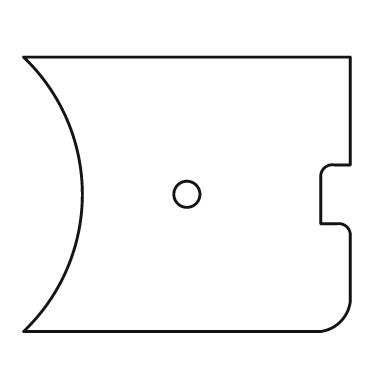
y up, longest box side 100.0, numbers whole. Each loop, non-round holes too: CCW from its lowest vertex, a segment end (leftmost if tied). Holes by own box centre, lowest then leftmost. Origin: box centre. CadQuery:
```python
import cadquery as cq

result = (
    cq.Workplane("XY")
    .moveTo(-50.0, -42.0)
    .lineTo(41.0, -42.0)
    .threePointArc((47.0, -39.0), (50.0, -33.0))
    .lineTo(50.0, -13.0)
    .threePointArc((49.0, -10.0), (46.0, -9.0))
    .lineTo(41.0, -9.0)
    .lineTo(41.0, 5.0)
    .threePointArc((42.0, 8.0), (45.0, 9.0))
    .lineTo(50.0, 9.0)
    .lineTo(50.0, 42.0)
    .lineTo(-50.0, 42.0)
    .threePointArc((-32.0, 0.0), (-50.0, -42.0))
    .close()
    .moveTo(0.0, 0.0)
    .circle(4.0)
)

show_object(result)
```